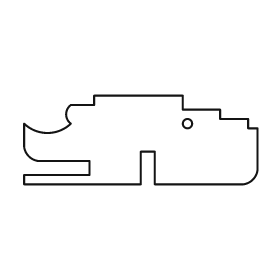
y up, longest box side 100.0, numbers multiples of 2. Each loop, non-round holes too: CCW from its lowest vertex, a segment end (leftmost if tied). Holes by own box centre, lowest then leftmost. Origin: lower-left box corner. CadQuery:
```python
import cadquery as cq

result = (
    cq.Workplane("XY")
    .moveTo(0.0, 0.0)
    .lineTo(50.0, 0.0)
    .lineTo(50.0, 14.0)
    .lineTo(56.0, 14.0)
    .lineTo(56.0, 0.0)
    .lineTo(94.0, 0.0)
    .threePointArc((98.0, 2.0), (100.0, 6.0))
    .lineTo(100.0, 24.0)
    .lineTo(96.0, 24.0)
    .lineTo(96.0, 28.0)
    .lineTo(84.0, 28.0)
    .lineTo(84.0, 32.0)
    .lineTo(68.0, 32.0)
    .lineTo(68.0, 38.0)
    .lineTo(30.0, 38.0)
    .lineTo(30.0, 34.0)
    .lineTo(20.0, 34.0)
    .threePointArc((18.0, 30.0), (20.0, 26.0))
    .threePointArc((10.0, 22.0), (0.0, 26.0))
    .lineTo(0.0, 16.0)
    .threePointArc((2.0, 12.0), (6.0, 10.0))
    .lineTo(28.0, 10.0)
    .lineTo(28.0, 4.0)
    .lineTo(0.0, 4.0)
    .close()
    .moveTo(70.0, 26.0)
    .circle(2.0)
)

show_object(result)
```